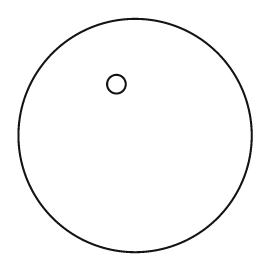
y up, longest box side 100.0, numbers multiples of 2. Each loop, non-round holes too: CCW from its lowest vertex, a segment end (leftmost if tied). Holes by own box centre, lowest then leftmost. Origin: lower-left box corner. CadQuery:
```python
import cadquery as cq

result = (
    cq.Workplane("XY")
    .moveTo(50.0, 50.0)
    .circle(50.0)
    .moveTo(42.0, 72.0)
    .circle(4.0)
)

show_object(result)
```